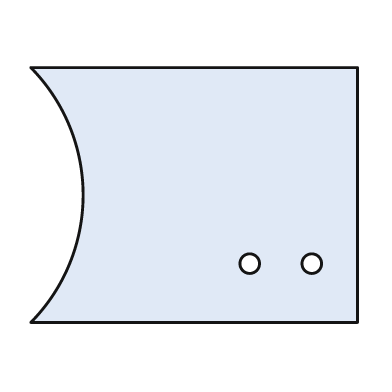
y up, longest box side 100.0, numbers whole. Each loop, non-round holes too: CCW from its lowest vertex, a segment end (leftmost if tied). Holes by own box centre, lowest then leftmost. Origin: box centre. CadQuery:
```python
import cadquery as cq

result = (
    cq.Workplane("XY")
    .moveTo(-50.0, -39.0)
    .lineTo(50.0, -39.0)
    .lineTo(50.0, 39.0)
    .lineTo(-50.0, 39.0)
    .threePointArc((-34.0, 0.0), (-50.0, -39.0))
    .close()
    .moveTo(17.0, -21.0)
    .circle(3.0)
    .moveTo(36.0, -21.0)
    .circle(3.0)
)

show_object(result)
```